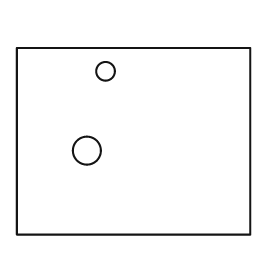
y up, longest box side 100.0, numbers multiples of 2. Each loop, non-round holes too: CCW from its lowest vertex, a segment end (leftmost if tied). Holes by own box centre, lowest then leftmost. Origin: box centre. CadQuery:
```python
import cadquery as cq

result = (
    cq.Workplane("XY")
    .moveTo(-50.0, -40.0)
    .lineTo(50.0, -40.0)
    .lineTo(50.0, 40.0)
    .lineTo(-50.0, 40.0)
    .close()
    .moveTo(-20.0, -4.0)
    .circle(6.0)
    .moveTo(-12.0, 30.0)
    .circle(4.0)
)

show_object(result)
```